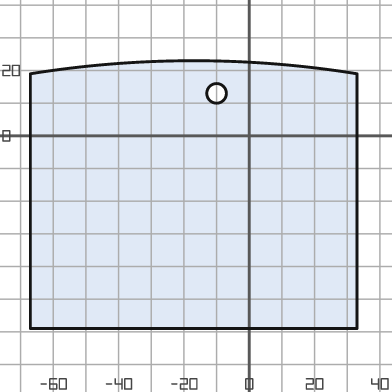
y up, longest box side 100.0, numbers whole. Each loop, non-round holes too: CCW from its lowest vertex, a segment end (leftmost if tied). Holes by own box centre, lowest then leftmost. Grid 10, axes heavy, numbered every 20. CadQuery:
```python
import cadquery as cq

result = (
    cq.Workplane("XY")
    .moveTo(-67.0, -59.0)
    .lineTo(33.0, -59.0)
    .lineTo(33.0, 19.0)
    .threePointArc((-17.0, 23.0), (-67.0, 19.0))
    .close()
    .moveTo(-10.0, 13.0)
    .circle(3.0)
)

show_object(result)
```